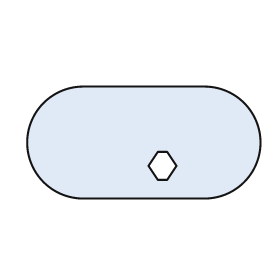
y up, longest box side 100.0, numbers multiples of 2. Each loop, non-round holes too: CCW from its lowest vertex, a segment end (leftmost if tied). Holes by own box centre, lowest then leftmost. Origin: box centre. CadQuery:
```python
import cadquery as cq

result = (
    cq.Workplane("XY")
    .moveTo(-26.0, -24.0)
    .lineTo(26.0, -24.0)
    .threePointArc((50.0, 0.0), (26.0, 24.0))
    .lineTo(-26.0, 24.0)
    .threePointArc((-50.0, 0.0), (-26.0, -24.0))
    .close()
    .moveTo(6.0, -16.0)
    .lineTo(10.0, -16.0)
    .lineTo(14.0, -10.0)
    .lineTo(10.0, -4.0)
    .lineTo(6.0, -4.0)
    .lineTo(2.0, -10.0)
    .close()
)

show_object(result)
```